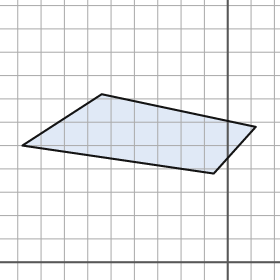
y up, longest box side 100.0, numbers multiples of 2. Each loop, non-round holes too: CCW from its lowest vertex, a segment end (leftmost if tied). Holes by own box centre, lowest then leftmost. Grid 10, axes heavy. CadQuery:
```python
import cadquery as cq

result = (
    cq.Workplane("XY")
    .moveTo(-6.0, 38.0)
    .lineTo(12.0, 58.0)
    .lineTo(-54.0, 72.0)
    .lineTo(-88.0, 50.0)
    .close()
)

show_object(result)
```